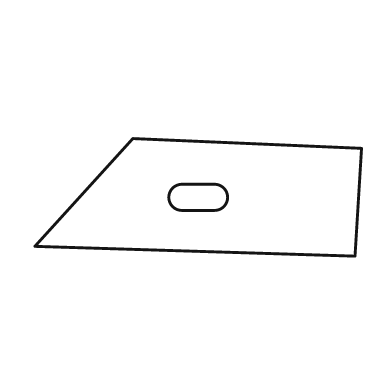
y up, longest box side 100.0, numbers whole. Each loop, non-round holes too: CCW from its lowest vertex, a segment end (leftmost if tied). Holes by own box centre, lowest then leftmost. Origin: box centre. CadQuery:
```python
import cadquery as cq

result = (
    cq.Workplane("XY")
    .moveTo(48.0, -18.0)
    .lineTo(50.0, 15.0)
    .lineTo(-20.0, 18.0)
    .lineTo(-50.0, -15.0)
    .close()
    .moveTo(-5.0, -4.0)
    .lineTo(5.0, -4.0)
    .threePointArc((9.0, 0.0), (5.0, 4.0))
    .lineTo(-5.0, 4.0)
    .threePointArc((-9.0, 0.0), (-5.0, -4.0))
    .close()
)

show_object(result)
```